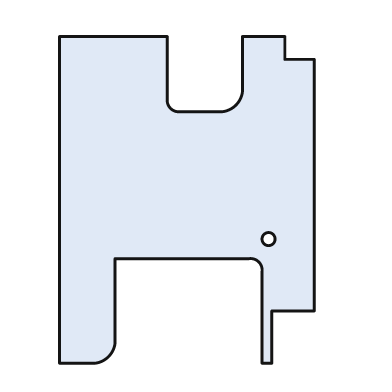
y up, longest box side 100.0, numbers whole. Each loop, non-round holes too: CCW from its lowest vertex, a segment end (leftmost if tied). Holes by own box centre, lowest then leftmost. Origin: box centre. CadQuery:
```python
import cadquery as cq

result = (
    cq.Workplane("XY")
    .moveTo(-39.0, -50.0)
    .lineTo(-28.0, -50.0)
    .threePointArc((-24.0, -48.0), (-22.0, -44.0))
    .lineTo(-22.0, -18.0)
    .lineTo(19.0, -18.0)
    .threePointArc((22.0, -19.0), (23.0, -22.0))
    .lineTo(23.0, -50.0)
    .lineTo(26.0, -50.0)
    .lineTo(26.0, -34.0)
    .lineTo(39.0, -34.0)
    .lineTo(39.0, 43.0)
    .lineTo(30.0, 43.0)
    .lineTo(30.0, 50.0)
    .lineTo(17.0, 50.0)
    .lineTo(17.0, 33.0)
    .threePointArc((15.0, 29.0), (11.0, 27.0))
    .lineTo(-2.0, 27.0)
    .threePointArc((-5.0, 28.0), (-6.0, 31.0))
    .lineTo(-6.0, 50.0)
    .lineTo(-39.0, 50.0)
    .close()
    .moveTo(25.0, -12.0)
    .circle(2.0)
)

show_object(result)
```